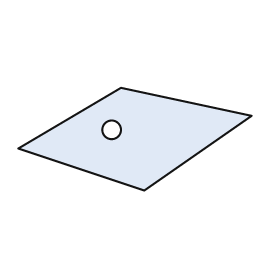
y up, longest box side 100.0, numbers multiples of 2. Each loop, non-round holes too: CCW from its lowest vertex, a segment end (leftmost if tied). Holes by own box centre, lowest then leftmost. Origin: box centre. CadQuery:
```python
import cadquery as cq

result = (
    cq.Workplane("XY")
    .moveTo(4.0, -22.0)
    .lineTo(50.0, 10.0)
    .lineTo(-6.0, 22.0)
    .lineTo(-50.0, -4.0)
    .close()
    .moveTo(-10.0, 4.0)
    .circle(4.0)
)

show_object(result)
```